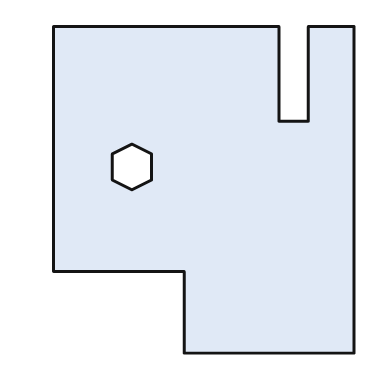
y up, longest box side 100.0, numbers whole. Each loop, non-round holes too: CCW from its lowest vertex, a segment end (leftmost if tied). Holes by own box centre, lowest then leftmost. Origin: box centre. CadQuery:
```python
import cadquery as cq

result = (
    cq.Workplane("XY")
    .moveTo(-6.0, -50.0)
    .lineTo(46.0, -50.0)
    .lineTo(46.0, 50.0)
    .lineTo(32.0, 50.0)
    .lineTo(32.0, 21.0)
    .lineTo(23.0, 21.0)
    .lineTo(23.0, 50.0)
    .lineTo(-46.0, 50.0)
    .lineTo(-46.0, -25.0)
    .lineTo(-6.0, -25.0)
    .close()
    .moveTo(-22.0, 0.0)
    .lineTo(-16.0, 3.0)
    .lineTo(-16.0, 11.0)
    .lineTo(-22.0, 14.0)
    .lineTo(-28.0, 11.0)
    .lineTo(-28.0, 3.0)
    .close()
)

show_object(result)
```